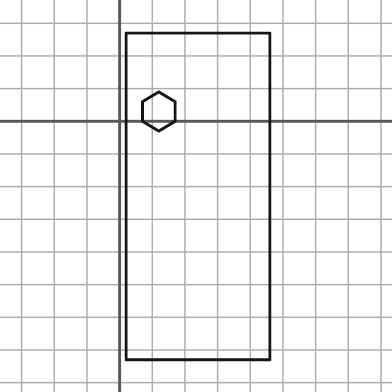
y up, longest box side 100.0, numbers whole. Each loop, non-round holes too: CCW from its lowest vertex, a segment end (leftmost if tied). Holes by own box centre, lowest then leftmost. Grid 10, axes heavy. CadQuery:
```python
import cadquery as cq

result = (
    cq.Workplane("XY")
    .moveTo(2.0, -73.0)
    .lineTo(46.0, -73.0)
    .lineTo(46.0, 27.0)
    .lineTo(2.0, 27.0)
    .close()
    .moveTo(12.0, -3.0)
    .lineTo(17.0, 0.0)
    .lineTo(17.0, 6.0)
    .lineTo(12.0, 9.0)
    .lineTo(7.0, 6.0)
    .lineTo(7.0, 0.0)
    .close()
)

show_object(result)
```